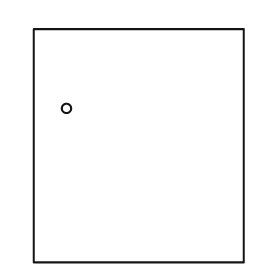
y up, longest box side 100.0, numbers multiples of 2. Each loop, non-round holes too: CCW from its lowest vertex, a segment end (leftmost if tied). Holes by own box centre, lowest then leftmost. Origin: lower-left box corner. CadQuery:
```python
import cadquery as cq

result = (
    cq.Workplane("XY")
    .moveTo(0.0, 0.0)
    .lineTo(90.0, 0.0)
    .lineTo(90.0, 100.0)
    .lineTo(0.0, 100.0)
    .close()
    .moveTo(14.0, 66.0)
    .circle(2.0)
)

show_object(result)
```